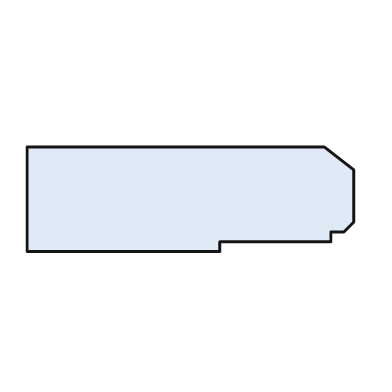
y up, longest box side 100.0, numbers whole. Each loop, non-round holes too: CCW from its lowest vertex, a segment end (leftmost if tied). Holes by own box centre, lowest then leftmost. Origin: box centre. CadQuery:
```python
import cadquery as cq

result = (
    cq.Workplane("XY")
    .moveTo(-50.0, -16.0)
    .lineTo(9.0, -16.0)
    .lineTo(9.0, -13.0)
    .lineTo(43.0, -13.0)
    .lineTo(43.0, -10.0)
    .lineTo(47.0, -10.0)
    .lineTo(50.0, -7.0)
    .lineTo(50.0, 9.0)
    .lineTo(41.0, 16.0)
    .lineTo(-50.0, 16.0)
    .close()
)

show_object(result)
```